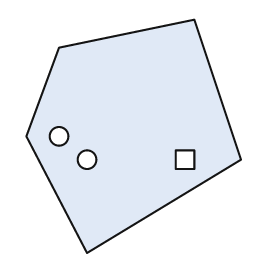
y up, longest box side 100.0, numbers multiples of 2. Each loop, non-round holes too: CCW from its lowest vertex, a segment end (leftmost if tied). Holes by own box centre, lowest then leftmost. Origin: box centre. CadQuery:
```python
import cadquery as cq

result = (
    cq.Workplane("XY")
    .moveTo(-20.0, -50.0)
    .lineTo(46.0, -10.0)
    .lineTo(26.0, 50.0)
    .lineTo(-32.0, 38.0)
    .lineTo(-46.0, 0.0)
    .close()
    .moveTo(-20.0, -10.0)
    .circle(4.0)
    .moveTo(18.0, -14.0)
    .lineTo(26.0, -14.0)
    .lineTo(26.0, -6.0)
    .lineTo(18.0, -6.0)
    .close()
    .moveTo(-32.0, 0.0)
    .circle(4.0)
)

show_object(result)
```